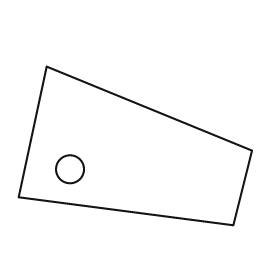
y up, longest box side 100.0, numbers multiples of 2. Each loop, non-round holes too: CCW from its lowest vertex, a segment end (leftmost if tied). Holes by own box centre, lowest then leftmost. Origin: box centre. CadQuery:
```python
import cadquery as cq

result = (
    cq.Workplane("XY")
    .moveTo(42.0, -34.0)
    .lineTo(50.0, -2.0)
    .lineTo(-38.0, 34.0)
    .lineTo(-50.0, -22.0)
    .close()
    .moveTo(-28.0, -10.0)
    .circle(6.0)
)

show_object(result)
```